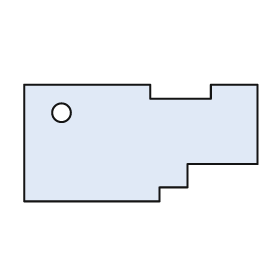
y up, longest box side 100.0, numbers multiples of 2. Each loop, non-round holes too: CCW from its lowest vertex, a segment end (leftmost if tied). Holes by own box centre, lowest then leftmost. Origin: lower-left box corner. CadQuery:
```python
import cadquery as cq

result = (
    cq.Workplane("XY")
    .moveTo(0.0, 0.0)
    .lineTo(58.0, 0.0)
    .lineTo(58.0, 6.0)
    .lineTo(70.0, 6.0)
    .lineTo(70.0, 16.0)
    .lineTo(100.0, 16.0)
    .lineTo(100.0, 50.0)
    .lineTo(80.0, 50.0)
    .lineTo(80.0, 44.0)
    .lineTo(54.0, 44.0)
    .lineTo(54.0, 50.0)
    .lineTo(0.0, 50.0)
    .close()
    .moveTo(16.0, 38.0)
    .circle(4.0)
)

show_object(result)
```